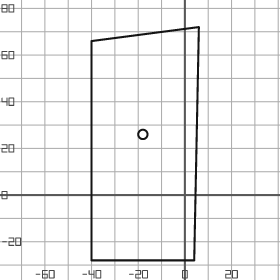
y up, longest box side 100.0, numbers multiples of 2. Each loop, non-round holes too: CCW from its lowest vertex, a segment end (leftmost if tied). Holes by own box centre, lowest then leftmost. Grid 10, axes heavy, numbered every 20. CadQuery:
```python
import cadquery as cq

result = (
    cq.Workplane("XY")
    .moveTo(-40.0, -28.0)
    .lineTo(4.0, -28.0)
    .lineTo(6.0, 72.0)
    .lineTo(-40.0, 66.0)
    .close()
    .moveTo(-18.0, 26.0)
    .circle(2.0)
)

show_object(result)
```